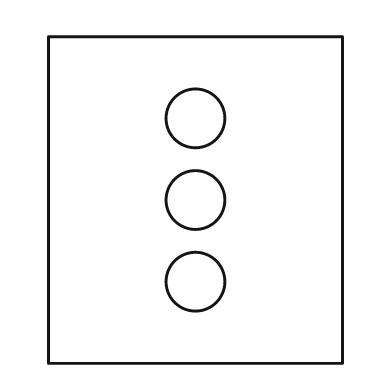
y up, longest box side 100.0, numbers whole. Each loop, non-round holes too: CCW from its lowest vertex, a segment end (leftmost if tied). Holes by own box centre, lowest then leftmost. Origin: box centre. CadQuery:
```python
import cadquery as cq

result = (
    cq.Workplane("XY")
    .moveTo(-45.0, -50.0)
    .lineTo(45.0, -50.0)
    .lineTo(45.0, 50.0)
    .lineTo(-45.0, 50.0)
    .close()
    .moveTo(0.0, -25.0)
    .circle(9.0)
    .moveTo(0.0, 0.0)
    .circle(9.0)
    .moveTo(0.0, 25.0)
    .circle(9.0)
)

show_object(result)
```